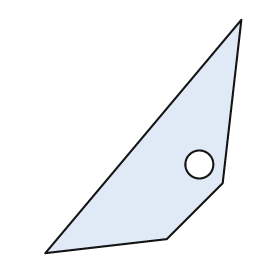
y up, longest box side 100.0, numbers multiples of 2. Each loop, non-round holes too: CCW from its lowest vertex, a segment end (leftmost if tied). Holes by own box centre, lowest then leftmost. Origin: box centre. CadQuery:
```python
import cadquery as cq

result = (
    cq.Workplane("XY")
    .moveTo(-42.0, -50.0)
    .lineTo(10.0, -44.0)
    .lineTo(34.0, -20.0)
    .lineTo(42.0, 50.0)
    .close()
    .moveTo(24.0, -12.0)
    .circle(6.0)
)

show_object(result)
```